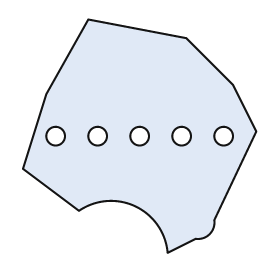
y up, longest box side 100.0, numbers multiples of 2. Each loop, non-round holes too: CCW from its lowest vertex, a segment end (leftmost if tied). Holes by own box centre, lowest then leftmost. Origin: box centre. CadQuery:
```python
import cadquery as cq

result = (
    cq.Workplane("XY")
    .moveTo(12.0, -50.0)
    .lineTo(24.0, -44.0)
    .threePointArc((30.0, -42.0), (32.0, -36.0))
    .lineTo(50.0, 2.0)
    .lineTo(40.0, 22.0)
    .lineTo(20.0, 42.0)
    .lineTo(-22.0, 50.0)
    .lineTo(-40.0, 18.0)
    .lineTo(-50.0, -14.0)
    .lineTo(-26.0, -32.0)
    .threePointArc((-2.0, -30.0), (12.0, -50.0))
    .close()
    .moveTo(-36.0, 0.0)
    .circle(4.0)
    .moveTo(-18.0, 0.0)
    .circle(4.0)
    .moveTo(0.0, 0.0)
    .circle(4.0)
    .moveTo(18.0, 0.0)
    .circle(4.0)
    .moveTo(36.0, 0.0)
    .circle(4.0)
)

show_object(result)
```